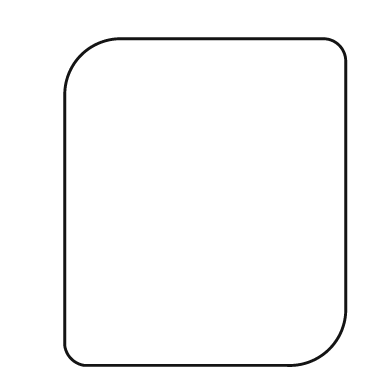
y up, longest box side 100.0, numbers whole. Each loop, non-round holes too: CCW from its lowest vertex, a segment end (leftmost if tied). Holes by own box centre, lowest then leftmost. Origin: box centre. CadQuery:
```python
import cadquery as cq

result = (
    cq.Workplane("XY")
    .moveTo(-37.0, -50.0)
    .lineTo(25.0, -50.0)
    .threePointArc((38.0, -45.0), (43.0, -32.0))
    .lineTo(43.0, 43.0)
    .threePointArc((41.0, 48.0), (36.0, 50.0))
    .lineTo(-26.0, 50.0)
    .threePointArc((-38.0, 45.0), (-43.0, 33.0))
    .lineTo(-43.0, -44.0)
    .threePointArc((-41.0, -48.0), (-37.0, -50.0))
    .close()
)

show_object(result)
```